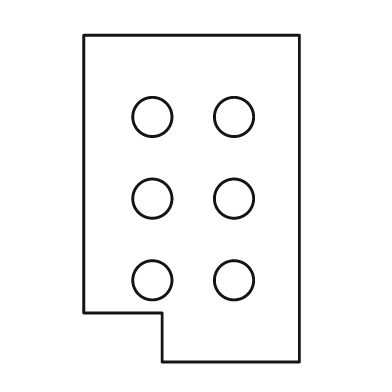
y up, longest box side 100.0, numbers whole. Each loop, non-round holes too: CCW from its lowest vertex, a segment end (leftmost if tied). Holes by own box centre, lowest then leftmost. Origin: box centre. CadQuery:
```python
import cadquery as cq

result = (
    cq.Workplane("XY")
    .moveTo(-9.0, -50.0)
    .lineTo(33.0, -50.0)
    .lineTo(33.0, 50.0)
    .lineTo(-33.0, 50.0)
    .lineTo(-33.0, -35.0)
    .lineTo(-9.0, -35.0)
    .close()
    .moveTo(-12.0, -25.0)
    .circle(6.0)
    .moveTo(13.0, -25.0)
    .circle(6.0)
    .moveTo(-12.0, 0.0)
    .circle(6.0)
    .moveTo(13.0, 0.0)
    .circle(6.0)
    .moveTo(-12.0, 25.0)
    .circle(6.0)
    .moveTo(13.0, 25.0)
    .circle(6.0)
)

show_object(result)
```